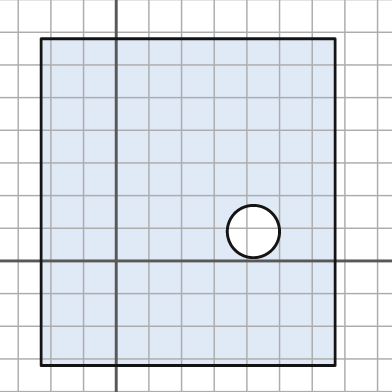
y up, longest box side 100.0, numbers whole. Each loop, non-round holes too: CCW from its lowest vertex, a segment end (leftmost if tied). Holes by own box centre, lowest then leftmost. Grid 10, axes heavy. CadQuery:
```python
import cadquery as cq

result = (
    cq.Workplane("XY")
    .moveTo(-23.0, -32.0)
    .lineTo(67.0, -32.0)
    .lineTo(67.0, 68.0)
    .lineTo(-23.0, 68.0)
    .close()
    .moveTo(42.0, 9.0)
    .circle(8.0)
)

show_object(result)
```